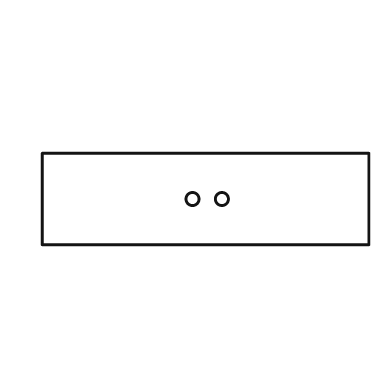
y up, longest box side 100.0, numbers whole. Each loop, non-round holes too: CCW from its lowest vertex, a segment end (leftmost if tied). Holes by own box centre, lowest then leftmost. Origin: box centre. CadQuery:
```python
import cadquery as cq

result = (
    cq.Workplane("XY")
    .moveTo(-50.0, -14.0)
    .lineTo(50.0, -14.0)
    .lineTo(50.0, 14.0)
    .lineTo(-50.0, 14.0)
    .close()
    .moveTo(-4.0, 0.0)
    .circle(2.0)
    .moveTo(5.0, 0.0)
    .circle(2.0)
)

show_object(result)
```